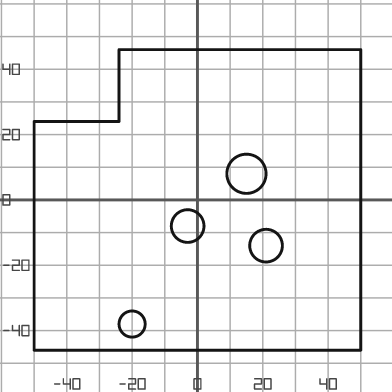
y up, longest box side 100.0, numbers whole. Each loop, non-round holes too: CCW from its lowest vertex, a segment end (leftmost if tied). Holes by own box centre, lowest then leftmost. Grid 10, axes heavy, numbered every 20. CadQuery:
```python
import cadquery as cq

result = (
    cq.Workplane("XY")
    .moveTo(-50.0, -46.0)
    .lineTo(50.0, -46.0)
    .lineTo(50.0, 46.0)
    .lineTo(-24.0, 46.0)
    .lineTo(-24.0, 24.0)
    .lineTo(-50.0, 24.0)
    .close()
    .moveTo(-20.0, -38.0)
    .circle(4.0)
    .moveTo(21.0, -14.0)
    .circle(5.0)
    .moveTo(-3.0, -8.0)
    .circle(5.0)
    .moveTo(15.0, 8.0)
    .circle(6.0)
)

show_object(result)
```